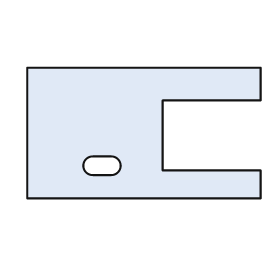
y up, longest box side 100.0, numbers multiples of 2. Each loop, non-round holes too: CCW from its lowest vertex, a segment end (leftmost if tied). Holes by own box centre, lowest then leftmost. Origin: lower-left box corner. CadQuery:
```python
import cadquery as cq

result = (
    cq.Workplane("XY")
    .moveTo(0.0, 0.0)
    .lineTo(100.0, 0.0)
    .lineTo(100.0, 12.0)
    .lineTo(58.0, 12.0)
    .lineTo(58.0, 42.0)
    .lineTo(100.0, 42.0)
    .lineTo(100.0, 56.0)
    .lineTo(0.0, 56.0)
    .close()
    .moveTo(28.0, 10.0)
    .lineTo(36.0, 10.0)
    .threePointArc((40.0, 14.0), (36.0, 18.0))
    .lineTo(28.0, 18.0)
    .threePointArc((24.0, 14.0), (28.0, 10.0))
    .close()
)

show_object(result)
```